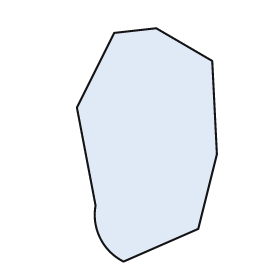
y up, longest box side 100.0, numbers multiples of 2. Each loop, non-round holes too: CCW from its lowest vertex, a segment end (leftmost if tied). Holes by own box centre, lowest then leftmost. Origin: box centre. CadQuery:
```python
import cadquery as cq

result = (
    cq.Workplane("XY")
    .moveTo(-10.0, -50.0)
    .lineTo(22.0, -36.0)
    .lineTo(30.0, -4.0)
    .lineTo(28.0, 36.0)
    .lineTo(4.0, 50.0)
    .lineTo(-14.0, 48.0)
    .lineTo(-30.0, 16.0)
    .lineTo(-22.0, -26.0)
    .threePointArc((-20.0, -40.0), (-10.0, -50.0))
    .close()
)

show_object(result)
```